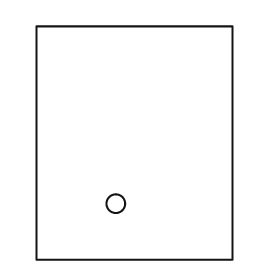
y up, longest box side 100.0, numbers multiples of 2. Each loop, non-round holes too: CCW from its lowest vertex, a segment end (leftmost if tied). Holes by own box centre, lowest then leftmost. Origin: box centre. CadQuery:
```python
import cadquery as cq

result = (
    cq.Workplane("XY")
    .moveTo(-42.0, -50.0)
    .lineTo(42.0, -50.0)
    .lineTo(42.0, 50.0)
    .lineTo(-42.0, 50.0)
    .close()
    .moveTo(-8.0, -26.0)
    .circle(4.0)
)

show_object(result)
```